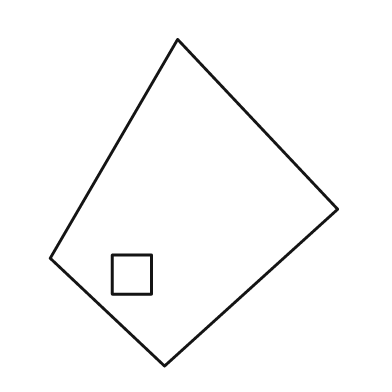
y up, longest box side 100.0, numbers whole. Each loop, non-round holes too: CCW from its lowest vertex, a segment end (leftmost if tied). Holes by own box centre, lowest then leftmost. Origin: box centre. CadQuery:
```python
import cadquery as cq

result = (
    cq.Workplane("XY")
    .moveTo(-9.0, -50.0)
    .lineTo(44.0, -2.0)
    .lineTo(-5.0, 50.0)
    .lineTo(-44.0, -17.0)
    .close()
    .moveTo(-25.0, -28.0)
    .lineTo(-13.0, -28.0)
    .lineTo(-13.0, -16.0)
    .lineTo(-25.0, -16.0)
    .close()
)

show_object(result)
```